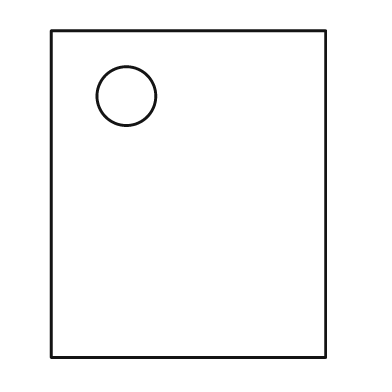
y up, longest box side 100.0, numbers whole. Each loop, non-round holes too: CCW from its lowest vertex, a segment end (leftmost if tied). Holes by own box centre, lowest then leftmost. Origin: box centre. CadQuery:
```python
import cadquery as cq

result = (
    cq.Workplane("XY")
    .moveTo(-42.0, -50.0)
    .lineTo(42.0, -50.0)
    .lineTo(42.0, 50.0)
    .lineTo(-42.0, 50.0)
    .close()
    .moveTo(-19.0, 30.0)
    .circle(9.0)
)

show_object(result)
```